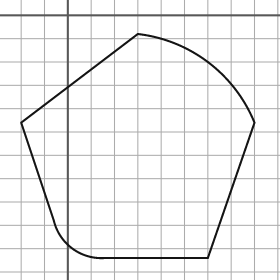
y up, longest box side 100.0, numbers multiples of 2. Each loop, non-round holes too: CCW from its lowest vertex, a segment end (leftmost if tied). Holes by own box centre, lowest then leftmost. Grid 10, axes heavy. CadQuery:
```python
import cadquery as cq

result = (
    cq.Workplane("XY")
    .moveTo(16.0, -104.0)
    .lineTo(60.0, -104.0)
    .lineTo(80.0, -46.0)
    .threePointArc((60.0, -20.0), (30.0, -8.0))
    .lineTo(-20.0, -46.0)
    .lineTo(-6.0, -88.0)
    .threePointArc((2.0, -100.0), (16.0, -104.0))
    .close()
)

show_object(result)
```